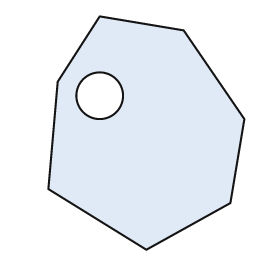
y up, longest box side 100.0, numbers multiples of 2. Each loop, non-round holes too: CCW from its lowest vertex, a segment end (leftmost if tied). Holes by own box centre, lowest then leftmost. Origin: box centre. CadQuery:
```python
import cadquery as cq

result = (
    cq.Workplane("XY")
    .moveTo(0.0, -50.0)
    .lineTo(36.0, -30.0)
    .lineTo(42.0, 6.0)
    .lineTo(16.0, 44.0)
    .lineTo(-20.0, 50.0)
    .lineTo(-38.0, 22.0)
    .lineTo(-42.0, -24.0)
    .close()
    .moveTo(-20.0, 16.0)
    .circle(10.0)
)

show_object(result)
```